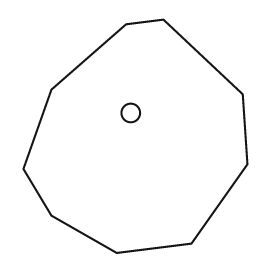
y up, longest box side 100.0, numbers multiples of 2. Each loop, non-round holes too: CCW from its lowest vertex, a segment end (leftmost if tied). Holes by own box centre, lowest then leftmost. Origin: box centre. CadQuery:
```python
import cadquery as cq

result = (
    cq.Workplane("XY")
    .moveTo(-8.0, -50.0)
    .lineTo(24.0, -46.0)
    .lineTo(48.0, -12.0)
    .lineTo(46.0, 18.0)
    .lineTo(12.0, 50.0)
    .lineTo(-4.0, 48.0)
    .lineTo(-36.0, 20.0)
    .lineTo(-48.0, -14.0)
    .lineTo(-36.0, -34.0)
    .close()
    .moveTo(-2.0, 10.0)
    .circle(4.0)
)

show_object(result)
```